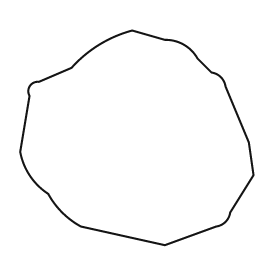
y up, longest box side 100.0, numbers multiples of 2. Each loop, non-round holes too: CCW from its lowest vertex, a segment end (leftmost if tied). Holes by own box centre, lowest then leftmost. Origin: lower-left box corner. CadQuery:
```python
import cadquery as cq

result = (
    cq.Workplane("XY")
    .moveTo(62.0, 0.0)
    .lineTo(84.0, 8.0)
    .threePointArc((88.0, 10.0), (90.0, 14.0))
    .lineTo(100.0, 30.0)
    .lineTo(98.0, 44.0)
    .lineTo(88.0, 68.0)
    .threePointArc((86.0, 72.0), (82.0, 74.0))
    .lineTo(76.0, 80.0)
    .threePointArc((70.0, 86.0), (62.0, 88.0))
    .lineTo(48.0, 92.0)
    .threePointArc((34.0, 86.0), (22.0, 76.0))
    .lineTo(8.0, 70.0)
    .threePointArc((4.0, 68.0), (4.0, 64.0))
    .lineTo(0.0, 40.0)
    .threePointArc((4.0, 30.0), (12.0, 22.0))
    .threePointArc((18.0, 14.0), (26.0, 8.0))
    .close()
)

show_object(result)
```